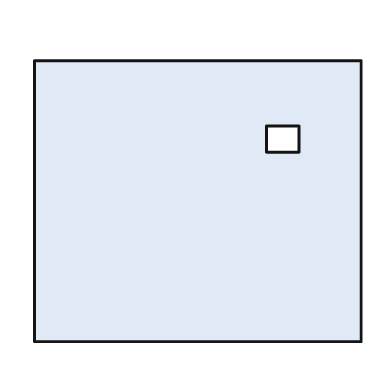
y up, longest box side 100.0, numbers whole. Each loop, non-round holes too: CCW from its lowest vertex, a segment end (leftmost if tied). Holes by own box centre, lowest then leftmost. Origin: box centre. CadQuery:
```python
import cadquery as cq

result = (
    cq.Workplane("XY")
    .moveTo(-50.0, -43.0)
    .lineTo(50.0, -43.0)
    .lineTo(50.0, 43.0)
    .lineTo(-50.0, 43.0)
    .close()
    .moveTo(21.0, 15.0)
    .lineTo(31.0, 15.0)
    .lineTo(31.0, 23.0)
    .lineTo(21.0, 23.0)
    .close()
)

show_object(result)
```